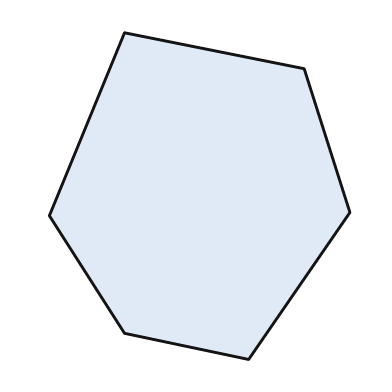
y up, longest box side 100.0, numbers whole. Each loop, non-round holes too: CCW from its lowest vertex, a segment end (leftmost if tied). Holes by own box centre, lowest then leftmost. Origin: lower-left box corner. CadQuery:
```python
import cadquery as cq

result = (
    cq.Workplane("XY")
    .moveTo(61.0, 0.0)
    .lineTo(92.0, 45.0)
    .lineTo(78.0, 89.0)
    .lineTo(23.0, 100.0)
    .lineTo(0.0, 44.0)
    .lineTo(23.0, 8.0)
    .close()
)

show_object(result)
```